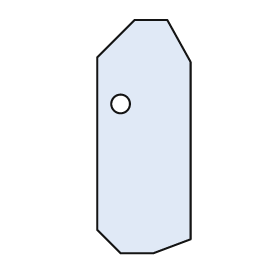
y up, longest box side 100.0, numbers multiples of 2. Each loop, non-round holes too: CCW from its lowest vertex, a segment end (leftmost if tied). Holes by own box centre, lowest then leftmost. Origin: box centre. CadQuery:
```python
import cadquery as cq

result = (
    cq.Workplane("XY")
    .moveTo(-10.0, -50.0)
    .lineTo(4.0, -50.0)
    .lineTo(20.0, -44.0)
    .lineTo(20.0, 32.0)
    .lineTo(10.0, 50.0)
    .lineTo(-4.0, 50.0)
    .lineTo(-20.0, 34.0)
    .lineTo(-20.0, -40.0)
    .close()
    .moveTo(-10.0, 14.0)
    .circle(4.0)
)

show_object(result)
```